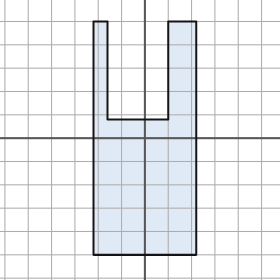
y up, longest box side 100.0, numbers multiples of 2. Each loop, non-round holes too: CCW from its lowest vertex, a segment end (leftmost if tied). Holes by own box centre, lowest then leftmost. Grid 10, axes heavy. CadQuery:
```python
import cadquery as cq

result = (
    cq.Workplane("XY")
    .moveTo(-22.0, -50.0)
    .lineTo(22.0, -50.0)
    .lineTo(22.0, 50.0)
    .lineTo(10.0, 50.0)
    .lineTo(10.0, 8.0)
    .lineTo(-16.0, 8.0)
    .lineTo(-16.0, 50.0)
    .lineTo(-22.0, 50.0)
    .close()
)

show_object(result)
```